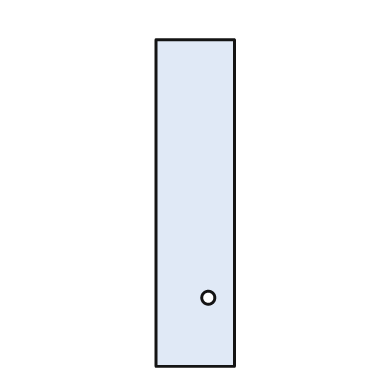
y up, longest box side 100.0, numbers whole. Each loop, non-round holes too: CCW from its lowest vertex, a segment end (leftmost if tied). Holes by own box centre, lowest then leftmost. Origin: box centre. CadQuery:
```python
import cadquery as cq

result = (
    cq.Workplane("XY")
    .moveTo(-12.0, -50.0)
    .lineTo(12.0, -50.0)
    .lineTo(12.0, 50.0)
    .lineTo(-12.0, 50.0)
    .close()
    .moveTo(4.0, -29.0)
    .circle(2.0)
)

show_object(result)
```